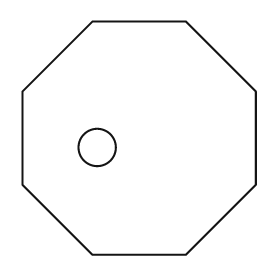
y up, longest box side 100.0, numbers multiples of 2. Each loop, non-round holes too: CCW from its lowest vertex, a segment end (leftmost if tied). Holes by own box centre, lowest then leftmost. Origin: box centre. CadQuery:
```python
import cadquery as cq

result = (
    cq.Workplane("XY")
    .moveTo(-20.0, -50.0)
    .lineTo(20.0, -50.0)
    .lineTo(50.0, -20.0)
    .lineTo(50.0, 20.0)
    .lineTo(20.0, 50.0)
    .lineTo(-20.0, 50.0)
    .lineTo(-50.0, 20.0)
    .lineTo(-50.0, -20.0)
    .close()
    .moveTo(-18.0, -4.0)
    .circle(8.0)
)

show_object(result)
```